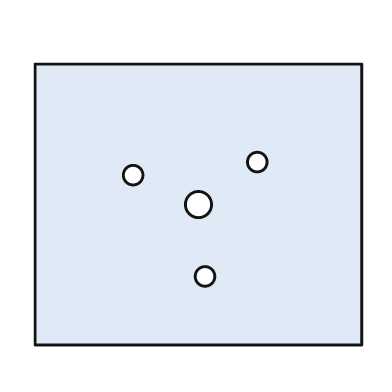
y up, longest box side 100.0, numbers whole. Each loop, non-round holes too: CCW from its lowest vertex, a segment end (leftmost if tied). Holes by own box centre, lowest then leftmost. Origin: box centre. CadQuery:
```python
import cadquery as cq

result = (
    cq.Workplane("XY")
    .moveTo(-50.0, -43.0)
    .lineTo(50.0, -43.0)
    .lineTo(50.0, 43.0)
    .lineTo(-50.0, 43.0)
    .close()
    .moveTo(2.0, -22.0)
    .circle(3.0)
    .moveTo(0.0, 0.0)
    .circle(4.0)
    .moveTo(-20.0, 9.0)
    .circle(3.0)
    .moveTo(18.0, 13.0)
    .circle(3.0)
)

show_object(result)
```